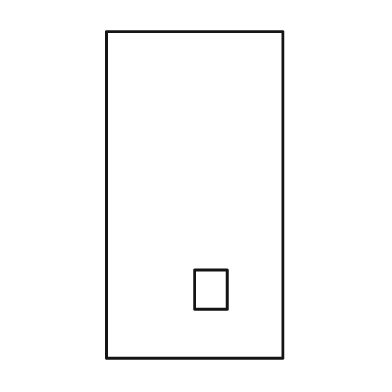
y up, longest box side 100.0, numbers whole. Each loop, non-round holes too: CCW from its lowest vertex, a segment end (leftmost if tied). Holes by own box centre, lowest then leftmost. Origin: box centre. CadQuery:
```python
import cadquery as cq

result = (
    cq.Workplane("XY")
    .moveTo(-27.0, -50.0)
    .lineTo(27.0, -50.0)
    .lineTo(27.0, 50.0)
    .lineTo(-27.0, 50.0)
    .close()
    .moveTo(0.0, -35.0)
    .lineTo(10.0, -35.0)
    .lineTo(10.0, -23.0)
    .lineTo(0.0, -23.0)
    .close()
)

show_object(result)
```